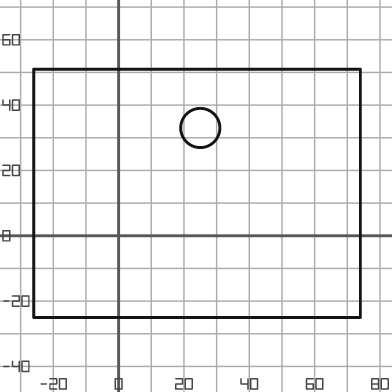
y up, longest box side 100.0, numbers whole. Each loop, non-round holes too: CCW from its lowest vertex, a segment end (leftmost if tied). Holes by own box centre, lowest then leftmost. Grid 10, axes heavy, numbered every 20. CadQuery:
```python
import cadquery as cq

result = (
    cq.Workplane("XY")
    .moveTo(-26.0, -25.0)
    .lineTo(74.0, -25.0)
    .lineTo(74.0, 51.0)
    .lineTo(-26.0, 51.0)
    .close()
    .moveTo(25.0, 33.0)
    .circle(6.0)
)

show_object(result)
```